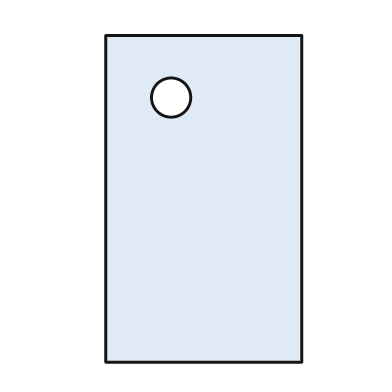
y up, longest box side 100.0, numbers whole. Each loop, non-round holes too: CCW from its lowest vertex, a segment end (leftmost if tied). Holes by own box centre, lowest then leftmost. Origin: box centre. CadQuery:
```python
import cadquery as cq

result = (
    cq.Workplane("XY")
    .moveTo(-30.0, -50.0)
    .lineTo(30.0, -50.0)
    .lineTo(30.0, 50.0)
    .lineTo(-30.0, 50.0)
    .close()
    .moveTo(-10.0, 31.0)
    .circle(6.0)
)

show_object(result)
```